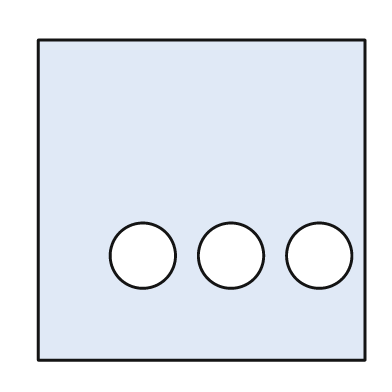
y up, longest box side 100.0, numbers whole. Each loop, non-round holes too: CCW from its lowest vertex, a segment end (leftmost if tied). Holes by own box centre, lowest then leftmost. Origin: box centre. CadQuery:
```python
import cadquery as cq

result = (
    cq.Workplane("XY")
    .moveTo(-50.0, -49.0)
    .lineTo(50.0, -49.0)
    .lineTo(50.0, 49.0)
    .lineTo(-50.0, 49.0)
    .close()
    .moveTo(-18.0, -17.0)
    .circle(10.0)
    .moveTo(9.0, -17.0)
    .circle(10.0)
    .moveTo(36.0, -17.0)
    .circle(10.0)
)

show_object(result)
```